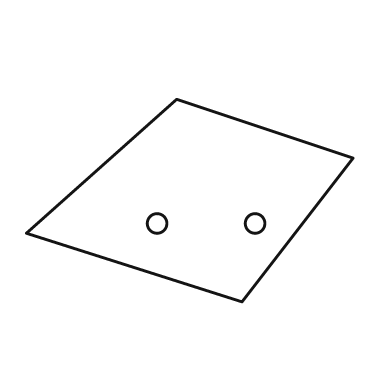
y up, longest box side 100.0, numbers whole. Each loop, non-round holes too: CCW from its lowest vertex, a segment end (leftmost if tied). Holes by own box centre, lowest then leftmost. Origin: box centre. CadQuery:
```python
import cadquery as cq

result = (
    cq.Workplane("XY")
    .moveTo(16.0, -31.0)
    .lineTo(50.0, 13.0)
    .lineTo(-4.0, 31.0)
    .lineTo(-50.0, -10.0)
    .close()
    .moveTo(-10.0, -7.0)
    .circle(3.0)
    .moveTo(20.0, -7.0)
    .circle(3.0)
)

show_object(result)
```